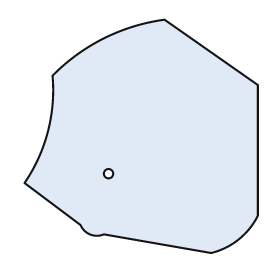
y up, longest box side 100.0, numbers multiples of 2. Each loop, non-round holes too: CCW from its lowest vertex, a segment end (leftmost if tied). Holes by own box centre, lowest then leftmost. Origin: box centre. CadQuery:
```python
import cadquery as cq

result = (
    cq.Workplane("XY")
    .moveTo(30.0, -50.0)
    .threePointArc((42.0, -44.0), (50.0, -34.0))
    .lineTo(50.0, 22.0)
    .lineTo(10.0, 50.0)
    .threePointArc((-16.0, 42.0), (-38.0, 26.0))
    .threePointArc((-40.0, 2.0), (-50.0, -20.0))
    .lineTo(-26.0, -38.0)
    .threePointArc((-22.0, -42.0), (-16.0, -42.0))
    .close()
    .moveTo(-14.0, -16.0)
    .circle(2.0)
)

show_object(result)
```